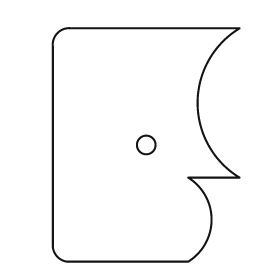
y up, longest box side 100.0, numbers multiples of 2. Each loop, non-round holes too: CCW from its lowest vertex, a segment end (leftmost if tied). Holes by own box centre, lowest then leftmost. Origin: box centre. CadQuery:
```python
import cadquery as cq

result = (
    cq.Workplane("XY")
    .moveTo(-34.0, -50.0)
    .lineTo(18.0, -50.0)
    .threePointArc((28.0, -32.0), (18.0, -14.0))
    .lineTo(40.0, -14.0)
    .threePointArc((22.0, 18.0), (40.0, 50.0))
    .lineTo(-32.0, 50.0)
    .threePointArc((-38.0, 48.0), (-40.0, 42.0))
    .lineTo(-40.0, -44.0)
    .threePointArc((-38.0, -48.0), (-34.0, -50.0))
    .close()
    .moveTo(0.0, 0.0)
    .circle(4.0)
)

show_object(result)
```